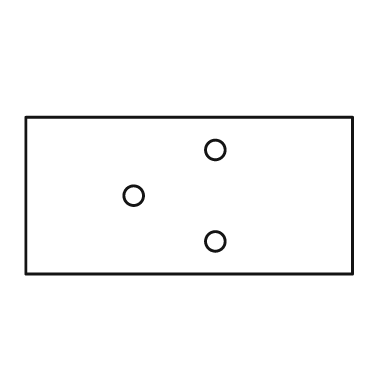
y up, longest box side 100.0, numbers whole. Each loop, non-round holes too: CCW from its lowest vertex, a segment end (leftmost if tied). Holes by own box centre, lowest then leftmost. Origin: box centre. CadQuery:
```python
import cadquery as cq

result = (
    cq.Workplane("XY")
    .moveTo(-50.0, -24.0)
    .lineTo(50.0, -24.0)
    .lineTo(50.0, 24.0)
    .lineTo(-50.0, 24.0)
    .close()
    .moveTo(8.0, -14.0)
    .circle(3.0)
    .moveTo(-17.0, 0.0)
    .circle(3.0)
    .moveTo(8.0, 14.0)
    .circle(3.0)
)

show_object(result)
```